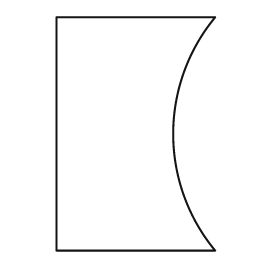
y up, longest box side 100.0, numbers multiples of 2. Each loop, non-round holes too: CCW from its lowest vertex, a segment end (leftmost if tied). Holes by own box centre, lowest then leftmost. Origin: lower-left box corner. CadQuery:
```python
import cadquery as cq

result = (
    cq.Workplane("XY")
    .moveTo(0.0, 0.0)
    .lineTo(68.0, 0.0)
    .threePointArc((50.0, 50.0), (68.0, 100.0))
    .lineTo(0.0, 100.0)
    .close()
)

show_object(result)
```